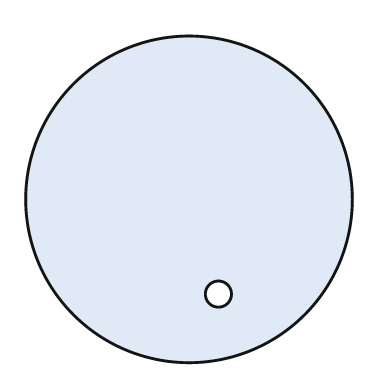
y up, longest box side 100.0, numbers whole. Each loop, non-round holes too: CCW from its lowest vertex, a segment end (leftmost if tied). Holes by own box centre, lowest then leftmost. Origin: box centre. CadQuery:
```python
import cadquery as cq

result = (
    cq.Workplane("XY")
    .moveTo(0.0, 0.0)
    .circle(50.0)
    .moveTo(9.0, -29.0)
    .circle(4.0)
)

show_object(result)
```